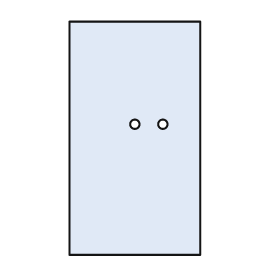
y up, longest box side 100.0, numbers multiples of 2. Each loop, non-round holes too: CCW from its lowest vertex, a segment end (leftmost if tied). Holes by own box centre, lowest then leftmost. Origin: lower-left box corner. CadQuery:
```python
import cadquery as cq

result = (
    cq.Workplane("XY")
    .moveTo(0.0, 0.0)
    .lineTo(56.0, 0.0)
    .lineTo(56.0, 100.0)
    .lineTo(0.0, 100.0)
    .close()
    .moveTo(28.0, 56.0)
    .circle(2.0)
    .moveTo(40.0, 56.0)
    .circle(2.0)
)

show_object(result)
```